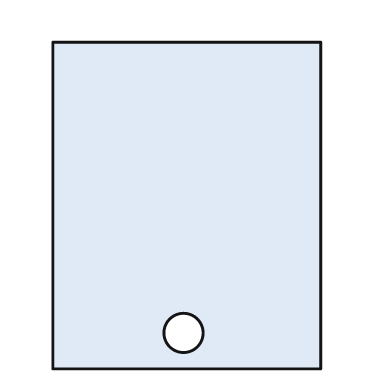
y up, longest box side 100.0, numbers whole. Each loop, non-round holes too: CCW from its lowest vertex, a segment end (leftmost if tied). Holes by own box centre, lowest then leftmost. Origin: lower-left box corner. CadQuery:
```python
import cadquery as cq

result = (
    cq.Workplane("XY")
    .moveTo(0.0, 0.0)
    .lineTo(82.0, 0.0)
    .lineTo(82.0, 100.0)
    .lineTo(0.0, 100.0)
    .close()
    .moveTo(40.0, 11.0)
    .circle(6.0)
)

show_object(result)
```